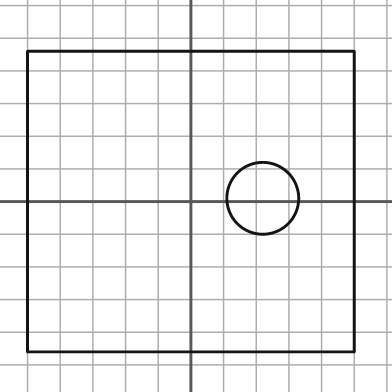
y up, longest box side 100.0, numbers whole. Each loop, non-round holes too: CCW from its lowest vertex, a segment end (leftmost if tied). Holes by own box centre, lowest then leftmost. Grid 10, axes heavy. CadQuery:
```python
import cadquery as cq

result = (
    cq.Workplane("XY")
    .moveTo(-50.0, -46.0)
    .lineTo(50.0, -46.0)
    .lineTo(50.0, 46.0)
    .lineTo(-50.0, 46.0)
    .close()
    .moveTo(22.0, 1.0)
    .circle(11.0)
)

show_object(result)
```